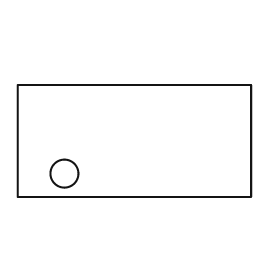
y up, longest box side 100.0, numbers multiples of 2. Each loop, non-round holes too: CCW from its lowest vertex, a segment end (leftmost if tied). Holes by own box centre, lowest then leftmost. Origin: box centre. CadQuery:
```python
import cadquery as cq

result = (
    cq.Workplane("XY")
    .moveTo(-50.0, -24.0)
    .lineTo(50.0, -24.0)
    .lineTo(50.0, 24.0)
    .lineTo(-50.0, 24.0)
    .close()
    .moveTo(-30.0, -14.0)
    .circle(6.0)
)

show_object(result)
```